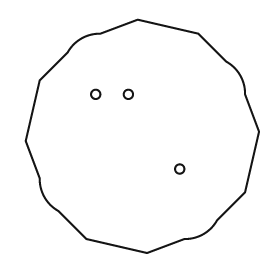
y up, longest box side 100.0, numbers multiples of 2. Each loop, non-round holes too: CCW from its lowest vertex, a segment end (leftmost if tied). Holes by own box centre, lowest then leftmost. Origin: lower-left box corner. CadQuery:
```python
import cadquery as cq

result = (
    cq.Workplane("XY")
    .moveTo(52.0, 0.0)
    .lineTo(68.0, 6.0)
    .threePointArc((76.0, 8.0), (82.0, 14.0))
    .lineTo(94.0, 26.0)
    .lineTo(100.0, 52.0)
    .lineTo(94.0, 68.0)
    .threePointArc((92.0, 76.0), (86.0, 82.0))
    .lineTo(74.0, 94.0)
    .lineTo(48.0, 100.0)
    .lineTo(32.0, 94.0)
    .threePointArc((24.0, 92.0), (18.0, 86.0))
    .lineTo(6.0, 74.0)
    .lineTo(0.0, 48.0)
    .lineTo(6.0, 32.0)
    .threePointArc((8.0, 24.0), (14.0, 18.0))
    .lineTo(26.0, 6.0)
    .close()
    .moveTo(66.0, 36.0)
    .circle(2.0)
    .moveTo(30.0, 68.0)
    .circle(2.0)
    .moveTo(44.0, 68.0)
    .circle(2.0)
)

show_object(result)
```